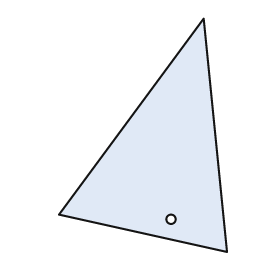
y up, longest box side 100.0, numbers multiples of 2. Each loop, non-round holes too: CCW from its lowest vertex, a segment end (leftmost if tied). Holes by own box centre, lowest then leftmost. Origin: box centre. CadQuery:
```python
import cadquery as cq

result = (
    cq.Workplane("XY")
    .moveTo(36.0, -50.0)
    .lineTo(26.0, 50.0)
    .lineTo(-36.0, -34.0)
    .close()
    .moveTo(12.0, -36.0)
    .circle(2.0)
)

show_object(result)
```